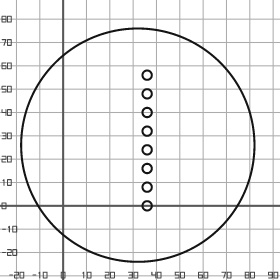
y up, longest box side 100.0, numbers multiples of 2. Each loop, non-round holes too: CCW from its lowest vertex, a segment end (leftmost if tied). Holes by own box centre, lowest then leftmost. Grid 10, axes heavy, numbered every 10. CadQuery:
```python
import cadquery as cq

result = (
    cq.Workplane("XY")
    .moveTo(32.0, 26.0)
    .circle(50.0)
    .moveTo(36.0, 0.0)
    .circle(2.0)
    .moveTo(36.0, 8.0)
    .circle(2.0)
    .moveTo(36.0, 16.0)
    .circle(2.0)
    .moveTo(36.0, 24.0)
    .circle(2.0)
    .moveTo(36.0, 32.0)
    .circle(2.0)
    .moveTo(36.0, 40.0)
    .circle(2.0)
    .moveTo(36.0, 48.0)
    .circle(2.0)
    .moveTo(36.0, 56.0)
    .circle(2.0)
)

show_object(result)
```